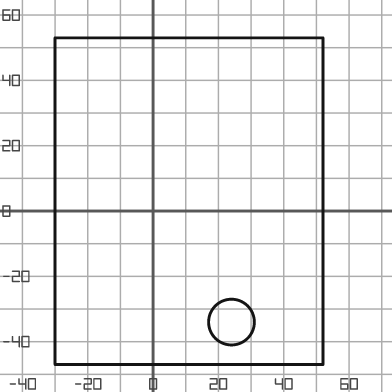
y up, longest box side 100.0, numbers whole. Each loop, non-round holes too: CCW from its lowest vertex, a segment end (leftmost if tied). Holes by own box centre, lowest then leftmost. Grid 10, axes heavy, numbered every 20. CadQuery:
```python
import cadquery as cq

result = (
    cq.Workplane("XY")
    .moveTo(-30.0, -47.0)
    .lineTo(52.0, -47.0)
    .lineTo(52.0, 53.0)
    .lineTo(-30.0, 53.0)
    .close()
    .moveTo(24.0, -34.0)
    .circle(7.0)
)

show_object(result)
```